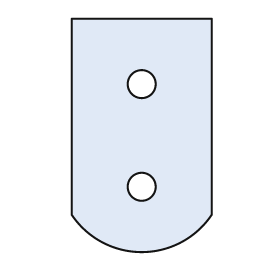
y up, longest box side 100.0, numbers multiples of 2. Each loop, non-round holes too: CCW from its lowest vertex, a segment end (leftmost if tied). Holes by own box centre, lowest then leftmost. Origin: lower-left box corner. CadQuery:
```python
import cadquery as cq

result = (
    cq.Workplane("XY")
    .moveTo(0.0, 16.0)
    .threePointArc((30.0, 0.0), (60.0, 16.0))
    .lineTo(60.0, 100.0)
    .lineTo(0.0, 100.0)
    .close()
    .moveTo(30.0, 28.0)
    .circle(6.0)
    .moveTo(30.0, 72.0)
    .circle(6.0)
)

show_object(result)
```